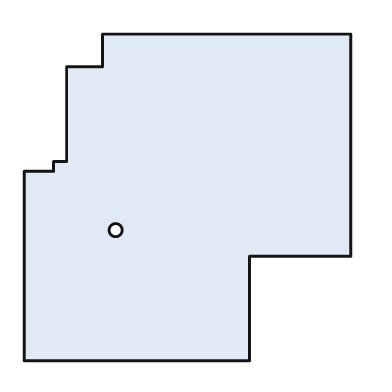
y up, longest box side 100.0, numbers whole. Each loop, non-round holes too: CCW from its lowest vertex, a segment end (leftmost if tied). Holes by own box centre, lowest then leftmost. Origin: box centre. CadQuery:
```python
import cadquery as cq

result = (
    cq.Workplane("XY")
    .moveTo(-50.0, -50.0)
    .lineTo(19.0, -50.0)
    .lineTo(19.0, -18.0)
    .lineTo(50.0, -18.0)
    .lineTo(50.0, 50.0)
    .lineTo(-26.0, 50.0)
    .lineTo(-26.0, 40.0)
    .lineTo(-37.0, 40.0)
    .lineTo(-37.0, 11.0)
    .lineTo(-41.0, 11.0)
    .lineTo(-41.0, 8.0)
    .lineTo(-50.0, 8.0)
    .close()
    .moveTo(-22.0, -10.0)
    .circle(2.0)
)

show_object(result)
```